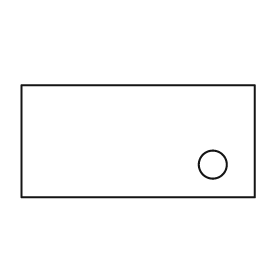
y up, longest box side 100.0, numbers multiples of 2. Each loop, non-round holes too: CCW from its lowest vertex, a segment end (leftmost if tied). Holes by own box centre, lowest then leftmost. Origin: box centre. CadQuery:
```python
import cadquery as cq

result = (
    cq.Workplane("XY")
    .moveTo(-50.0, -24.0)
    .lineTo(50.0, -24.0)
    .lineTo(50.0, 24.0)
    .lineTo(-50.0, 24.0)
    .close()
    .moveTo(32.0, -10.0)
    .circle(6.0)
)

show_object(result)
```